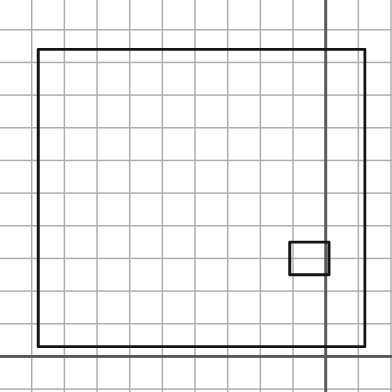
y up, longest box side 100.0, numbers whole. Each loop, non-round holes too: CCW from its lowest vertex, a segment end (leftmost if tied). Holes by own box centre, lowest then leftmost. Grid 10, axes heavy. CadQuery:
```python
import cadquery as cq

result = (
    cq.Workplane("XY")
    .moveTo(-88.0, 3.0)
    .lineTo(12.0, 3.0)
    .lineTo(12.0, 94.0)
    .lineTo(-88.0, 94.0)
    .close()
    .moveTo(-11.0, 25.0)
    .lineTo(1.0, 25.0)
    .lineTo(1.0, 35.0)
    .lineTo(-11.0, 35.0)
    .close()
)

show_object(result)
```